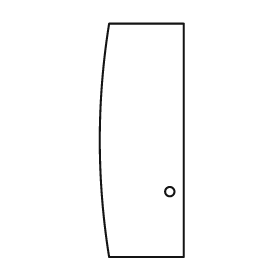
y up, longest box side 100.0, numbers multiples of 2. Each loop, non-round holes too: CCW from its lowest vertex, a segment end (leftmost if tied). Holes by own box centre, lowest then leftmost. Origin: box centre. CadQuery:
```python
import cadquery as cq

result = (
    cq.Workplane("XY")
    .moveTo(-14.0, -50.0)
    .lineTo(18.0, -50.0)
    .lineTo(18.0, 50.0)
    .lineTo(-14.0, 50.0)
    .threePointArc((-18.0, 0.0), (-14.0, -50.0))
    .close()
    .moveTo(12.0, -22.0)
    .circle(2.0)
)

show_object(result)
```